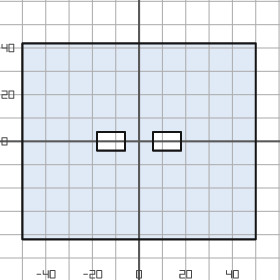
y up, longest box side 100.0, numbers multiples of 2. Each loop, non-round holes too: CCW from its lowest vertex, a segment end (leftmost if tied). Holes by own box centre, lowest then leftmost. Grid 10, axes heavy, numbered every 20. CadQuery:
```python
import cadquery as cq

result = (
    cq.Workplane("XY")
    .moveTo(-50.0, -42.0)
    .lineTo(50.0, -42.0)
    .lineTo(50.0, 42.0)
    .lineTo(-50.0, 42.0)
    .close()
    .moveTo(-18.0, -4.0)
    .lineTo(-6.0, -4.0)
    .lineTo(-6.0, 4.0)
    .lineTo(-18.0, 4.0)
    .close()
    .moveTo(6.0, -4.0)
    .lineTo(18.0, -4.0)
    .lineTo(18.0, 4.0)
    .lineTo(6.0, 4.0)
    .close()
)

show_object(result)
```